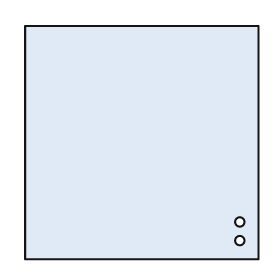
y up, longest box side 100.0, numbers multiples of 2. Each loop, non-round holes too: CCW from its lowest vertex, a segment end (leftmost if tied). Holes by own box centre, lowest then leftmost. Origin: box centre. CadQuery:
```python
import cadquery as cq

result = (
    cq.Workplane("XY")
    .moveTo(-50.0, -50.0)
    .lineTo(50.0, -50.0)
    .lineTo(50.0, 50.0)
    .lineTo(-50.0, 50.0)
    .close()
    .moveTo(42.0, -42.0)
    .circle(2.0)
    .moveTo(42.0, -34.0)
    .circle(2.0)
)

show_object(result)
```